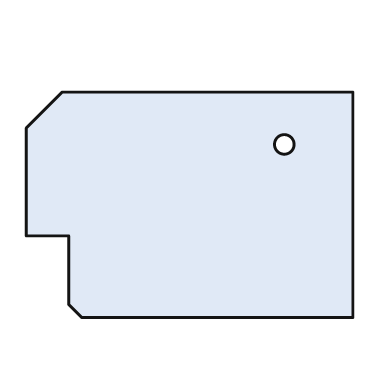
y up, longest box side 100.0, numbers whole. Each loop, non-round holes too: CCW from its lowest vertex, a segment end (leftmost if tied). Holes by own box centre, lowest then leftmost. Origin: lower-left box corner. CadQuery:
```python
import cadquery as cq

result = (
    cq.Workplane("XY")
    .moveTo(17.0, 0.0)
    .lineTo(100.0, 0.0)
    .lineTo(100.0, 69.0)
    .lineTo(11.0, 69.0)
    .lineTo(0.0, 58.0)
    .lineTo(0.0, 25.0)
    .lineTo(13.0, 25.0)
    .lineTo(13.0, 4.0)
    .close()
    .moveTo(79.0, 53.0)
    .circle(3.0)
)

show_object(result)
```